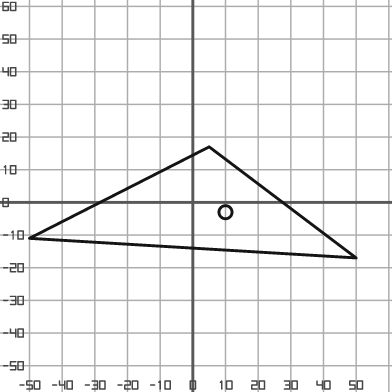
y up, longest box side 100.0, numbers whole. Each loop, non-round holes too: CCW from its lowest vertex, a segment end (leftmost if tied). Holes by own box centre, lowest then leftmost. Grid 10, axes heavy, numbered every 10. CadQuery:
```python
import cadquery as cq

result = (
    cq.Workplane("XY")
    .moveTo(50.0, -17.0)
    .lineTo(5.0, 17.0)
    .lineTo(-50.0, -11.0)
    .close()
    .moveTo(10.0, -3.0)
    .circle(2.0)
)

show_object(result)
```